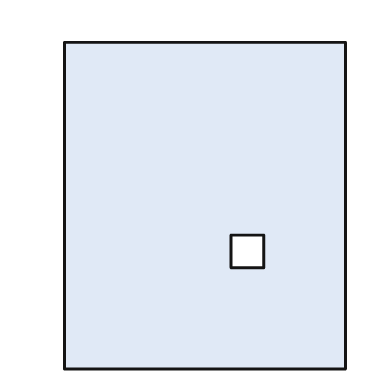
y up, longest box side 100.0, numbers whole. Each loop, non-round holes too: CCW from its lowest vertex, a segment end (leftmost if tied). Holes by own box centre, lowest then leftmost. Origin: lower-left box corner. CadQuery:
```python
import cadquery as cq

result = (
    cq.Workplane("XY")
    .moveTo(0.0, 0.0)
    .lineTo(86.0, 0.0)
    .lineTo(86.0, 100.0)
    .lineTo(0.0, 100.0)
    .close()
    .moveTo(51.0, 31.0)
    .lineTo(61.0, 31.0)
    .lineTo(61.0, 41.0)
    .lineTo(51.0, 41.0)
    .close()
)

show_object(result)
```